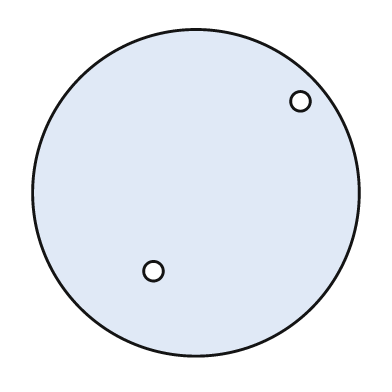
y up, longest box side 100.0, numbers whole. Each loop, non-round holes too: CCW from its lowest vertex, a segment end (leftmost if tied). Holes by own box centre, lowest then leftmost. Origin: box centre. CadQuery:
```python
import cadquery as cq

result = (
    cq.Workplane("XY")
    .moveTo(0.0, 0.0)
    .circle(50.0)
    .moveTo(-13.0, -24.0)
    .circle(3.0)
    .moveTo(32.0, 28.0)
    .circle(3.0)
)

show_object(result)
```